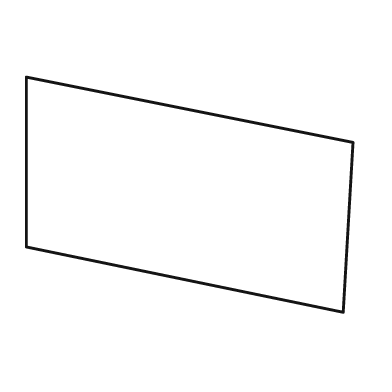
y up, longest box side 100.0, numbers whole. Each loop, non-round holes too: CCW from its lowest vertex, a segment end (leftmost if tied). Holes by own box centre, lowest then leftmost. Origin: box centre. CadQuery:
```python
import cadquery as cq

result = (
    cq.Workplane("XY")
    .moveTo(47.0, -36.0)
    .lineTo(50.0, 16.0)
    .lineTo(-50.0, 36.0)
    .lineTo(-50.0, -16.0)
    .close()
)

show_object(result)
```